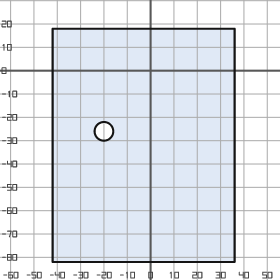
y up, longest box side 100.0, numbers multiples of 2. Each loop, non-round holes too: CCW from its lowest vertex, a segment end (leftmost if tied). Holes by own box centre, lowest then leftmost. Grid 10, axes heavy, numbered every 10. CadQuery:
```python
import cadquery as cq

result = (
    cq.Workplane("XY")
    .moveTo(-42.0, -82.0)
    .lineTo(36.0, -82.0)
    .lineTo(36.0, 18.0)
    .lineTo(-42.0, 18.0)
    .close()
    .moveTo(-20.0, -26.0)
    .circle(4.0)
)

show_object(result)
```